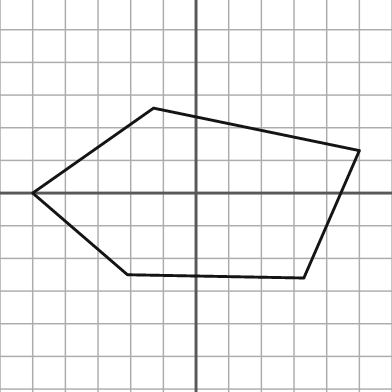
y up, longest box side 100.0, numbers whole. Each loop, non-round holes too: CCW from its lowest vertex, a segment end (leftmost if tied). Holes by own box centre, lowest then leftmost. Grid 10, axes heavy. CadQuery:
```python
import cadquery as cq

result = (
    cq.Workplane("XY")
    .moveTo(33.0, -26.0)
    .lineTo(50.0, 13.0)
    .lineTo(-13.0, 26.0)
    .lineTo(-50.0, 0.0)
    .lineTo(-21.0, -25.0)
    .close()
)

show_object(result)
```